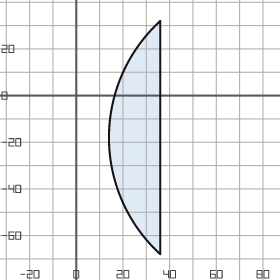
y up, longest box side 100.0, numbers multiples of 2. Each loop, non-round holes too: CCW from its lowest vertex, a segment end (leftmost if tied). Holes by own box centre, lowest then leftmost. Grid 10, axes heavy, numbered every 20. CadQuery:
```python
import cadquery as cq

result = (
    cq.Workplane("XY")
    .moveTo(36.0, -68.0)
    .lineTo(36.0, 32.0)
    .threePointArc((14.0, -18.0), (36.0, -68.0))
    .close()
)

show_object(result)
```